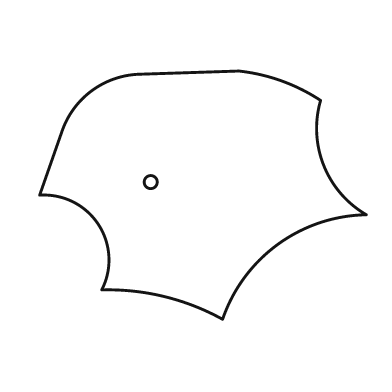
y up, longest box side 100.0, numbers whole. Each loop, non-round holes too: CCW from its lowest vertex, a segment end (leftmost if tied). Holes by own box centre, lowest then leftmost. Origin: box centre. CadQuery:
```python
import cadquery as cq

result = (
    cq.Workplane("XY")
    .moveTo(6.0, -38.0)
    .threePointArc((23.0, -15.0), (50.0, -6.0))
    .threePointArc((37.0, 9.0), (36.0, 29.0))
    .threePointArc((24.0, 35.0), (11.0, 38.0))
    .lineTo(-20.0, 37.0)
    .threePointArc((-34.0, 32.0), (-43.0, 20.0))
    .lineTo(-50.0, 0.0)
    .threePointArc((-32.0, -9.0), (-31.0, -29.0))
    .threePointArc((-12.0, -31.0), (6.0, -38.0))
    .close()
    .moveTo(-16.0, 4.0)
    .circle(2.0)
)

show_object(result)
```